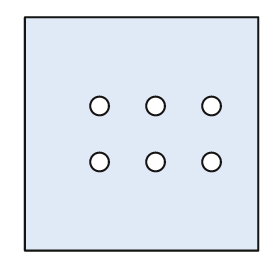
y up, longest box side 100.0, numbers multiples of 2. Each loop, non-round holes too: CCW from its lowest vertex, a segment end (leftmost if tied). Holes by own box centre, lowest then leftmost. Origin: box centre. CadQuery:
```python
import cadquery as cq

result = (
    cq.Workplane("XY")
    .moveTo(-50.0, -50.0)
    .lineTo(50.0, -50.0)
    .lineTo(50.0, 50.0)
    .lineTo(-50.0, 50.0)
    .close()
    .moveTo(-18.0, -12.0)
    .circle(4.0)
    .moveTo(6.0, -12.0)
    .circle(4.0)
    .moveTo(30.0, -12.0)
    .circle(4.0)
    .moveTo(-18.0, 12.0)
    .circle(4.0)
    .moveTo(6.0, 12.0)
    .circle(4.0)
    .moveTo(30.0, 12.0)
    .circle(4.0)
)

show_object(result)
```